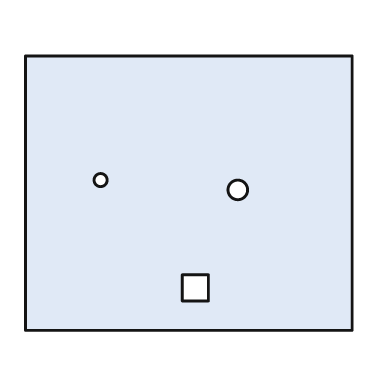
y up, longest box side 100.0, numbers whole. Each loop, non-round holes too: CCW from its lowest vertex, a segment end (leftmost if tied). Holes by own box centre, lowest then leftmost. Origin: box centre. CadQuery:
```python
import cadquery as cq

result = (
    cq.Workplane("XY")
    .moveTo(-50.0, -42.0)
    .lineTo(50.0, -42.0)
    .lineTo(50.0, 42.0)
    .lineTo(-50.0, 42.0)
    .close()
    .moveTo(-2.0, -33.0)
    .lineTo(6.0, -33.0)
    .lineTo(6.0, -25.0)
    .lineTo(-2.0, -25.0)
    .close()
    .moveTo(15.0, 1.0)
    .circle(3.0)
    .moveTo(-27.0, 4.0)
    .circle(2.0)
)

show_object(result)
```